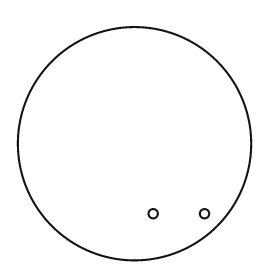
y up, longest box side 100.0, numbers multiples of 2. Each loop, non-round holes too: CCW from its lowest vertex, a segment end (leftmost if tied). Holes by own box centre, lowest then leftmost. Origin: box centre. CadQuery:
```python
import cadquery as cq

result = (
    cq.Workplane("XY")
    .moveTo(0.0, 0.0)
    .circle(50.0)
    .moveTo(8.0, -30.0)
    .circle(2.0)
    .moveTo(30.0, -30.0)
    .circle(2.0)
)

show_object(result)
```